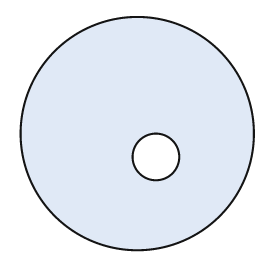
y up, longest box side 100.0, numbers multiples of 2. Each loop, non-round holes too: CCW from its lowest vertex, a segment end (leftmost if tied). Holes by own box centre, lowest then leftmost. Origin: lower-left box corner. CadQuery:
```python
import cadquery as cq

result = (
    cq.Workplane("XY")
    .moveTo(50.0, 50.0)
    .circle(50.0)
    .moveTo(58.0, 40.0)
    .circle(10.0)
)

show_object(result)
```